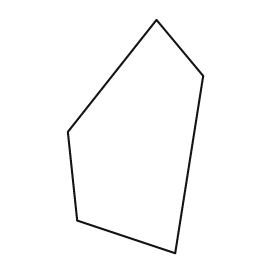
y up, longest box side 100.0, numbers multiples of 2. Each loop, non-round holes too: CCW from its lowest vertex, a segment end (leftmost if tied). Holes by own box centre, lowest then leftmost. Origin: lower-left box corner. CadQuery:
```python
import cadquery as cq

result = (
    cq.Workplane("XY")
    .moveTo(46.0, 0.0)
    .lineTo(58.0, 76.0)
    .lineTo(38.0, 100.0)
    .lineTo(0.0, 52.0)
    .lineTo(4.0, 14.0)
    .close()
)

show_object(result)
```